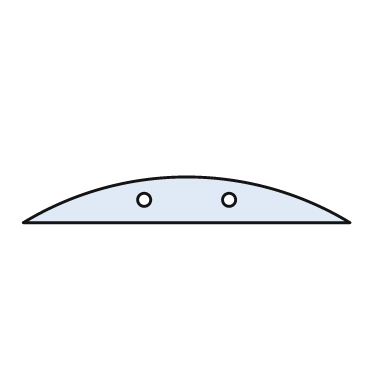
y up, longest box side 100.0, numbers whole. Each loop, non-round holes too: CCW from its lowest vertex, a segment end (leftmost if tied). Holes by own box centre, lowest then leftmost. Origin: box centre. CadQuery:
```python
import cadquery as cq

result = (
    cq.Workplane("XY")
    .moveTo(-50.0, -7.0)
    .lineTo(50.0, -7.0)
    .threePointArc((0.0, 7.0), (-50.0, -7.0))
    .close()
    .moveTo(-13.0, 0.0)
    .circle(2.0)
    .moveTo(13.0, 0.0)
    .circle(2.0)
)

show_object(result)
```